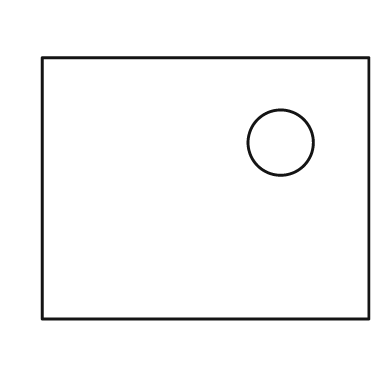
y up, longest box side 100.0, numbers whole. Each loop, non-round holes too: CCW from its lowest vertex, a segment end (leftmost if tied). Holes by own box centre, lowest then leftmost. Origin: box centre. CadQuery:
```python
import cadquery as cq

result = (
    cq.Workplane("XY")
    .moveTo(-50.0, -40.0)
    .lineTo(50.0, -40.0)
    .lineTo(50.0, 40.0)
    .lineTo(-50.0, 40.0)
    .close()
    .moveTo(23.0, 14.0)
    .circle(10.0)
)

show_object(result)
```